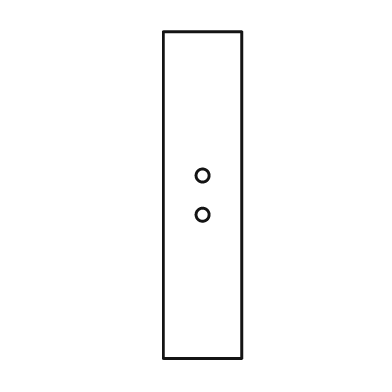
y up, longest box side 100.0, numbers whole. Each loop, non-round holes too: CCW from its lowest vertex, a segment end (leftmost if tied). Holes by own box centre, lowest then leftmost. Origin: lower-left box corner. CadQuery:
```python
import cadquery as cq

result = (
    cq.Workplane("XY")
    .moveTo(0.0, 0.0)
    .lineTo(24.0, 0.0)
    .lineTo(24.0, 100.0)
    .lineTo(0.0, 100.0)
    .close()
    .moveTo(12.0, 44.0)
    .circle(2.0)
    .moveTo(12.0, 56.0)
    .circle(2.0)
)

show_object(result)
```